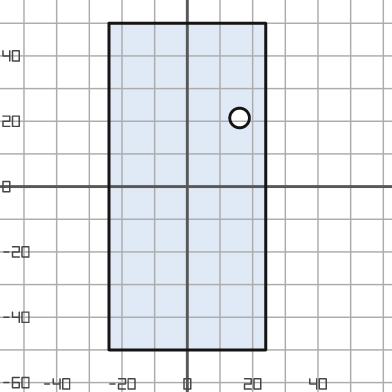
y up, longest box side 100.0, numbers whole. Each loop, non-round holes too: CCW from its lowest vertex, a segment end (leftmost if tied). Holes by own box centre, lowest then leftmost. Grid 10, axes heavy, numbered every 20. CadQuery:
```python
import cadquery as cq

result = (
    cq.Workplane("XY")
    .moveTo(-24.0, -50.0)
    .lineTo(24.0, -50.0)
    .lineTo(24.0, 50.0)
    .lineTo(-24.0, 50.0)
    .close()
    .moveTo(16.0, 21.0)
    .circle(3.0)
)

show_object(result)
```